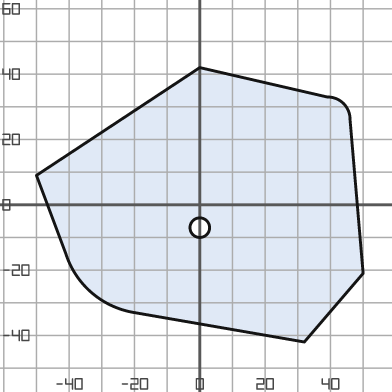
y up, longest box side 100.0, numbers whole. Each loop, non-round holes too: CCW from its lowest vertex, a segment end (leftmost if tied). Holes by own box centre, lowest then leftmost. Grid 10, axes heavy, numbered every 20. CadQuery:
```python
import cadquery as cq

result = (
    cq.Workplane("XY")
    .moveTo(32.0, -42.0)
    .lineTo(50.0, -21.0)
    .lineTo(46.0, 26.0)
    .threePointArc((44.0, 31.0), (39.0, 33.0))
    .lineTo(0.0, 42.0)
    .lineTo(-50.0, 9.0)
    .lineTo(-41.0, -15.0)
    .threePointArc((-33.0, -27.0), (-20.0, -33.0))
    .close()
    .moveTo(0.0, -7.0)
    .circle(3.0)
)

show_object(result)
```